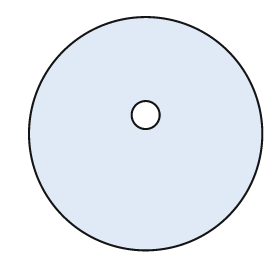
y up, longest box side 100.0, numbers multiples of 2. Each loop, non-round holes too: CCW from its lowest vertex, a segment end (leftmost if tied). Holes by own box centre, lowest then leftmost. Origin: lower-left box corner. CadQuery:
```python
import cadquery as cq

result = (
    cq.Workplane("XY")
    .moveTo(50.0, 50.0)
    .circle(50.0)
    .moveTo(50.0, 58.0)
    .circle(6.0)
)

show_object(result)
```